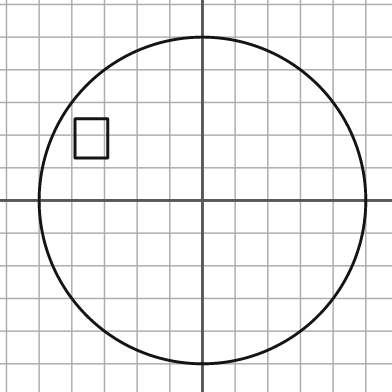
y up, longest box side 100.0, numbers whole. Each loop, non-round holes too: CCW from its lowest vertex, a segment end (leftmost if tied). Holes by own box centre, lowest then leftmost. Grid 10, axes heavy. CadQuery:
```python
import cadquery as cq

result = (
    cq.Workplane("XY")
    .moveTo(0.0, 0.0)
    .circle(50.0)
    .moveTo(-39.0, 13.0)
    .lineTo(-29.0, 13.0)
    .lineTo(-29.0, 25.0)
    .lineTo(-39.0, 25.0)
    .close()
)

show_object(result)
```